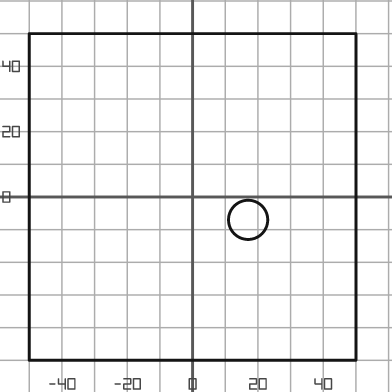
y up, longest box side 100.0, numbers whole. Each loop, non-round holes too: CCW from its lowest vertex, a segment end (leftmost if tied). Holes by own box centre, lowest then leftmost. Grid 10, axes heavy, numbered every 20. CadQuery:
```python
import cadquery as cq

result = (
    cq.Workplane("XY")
    .moveTo(-50.0, -50.0)
    .lineTo(50.0, -50.0)
    .lineTo(50.0, 50.0)
    .lineTo(-50.0, 50.0)
    .close()
    .moveTo(17.0, -7.0)
    .circle(6.0)
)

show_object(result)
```